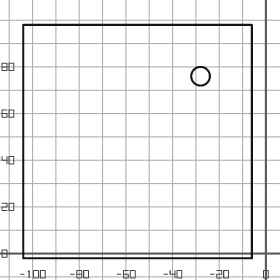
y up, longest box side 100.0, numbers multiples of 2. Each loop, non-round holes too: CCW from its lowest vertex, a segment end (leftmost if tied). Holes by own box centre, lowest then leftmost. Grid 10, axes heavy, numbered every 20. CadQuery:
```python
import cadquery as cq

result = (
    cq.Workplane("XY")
    .moveTo(-104.0, -2.0)
    .lineTo(-6.0, -2.0)
    .lineTo(-6.0, 98.0)
    .lineTo(-104.0, 98.0)
    .close()
    .moveTo(-28.0, 76.0)
    .circle(4.0)
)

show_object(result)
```